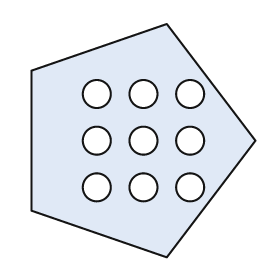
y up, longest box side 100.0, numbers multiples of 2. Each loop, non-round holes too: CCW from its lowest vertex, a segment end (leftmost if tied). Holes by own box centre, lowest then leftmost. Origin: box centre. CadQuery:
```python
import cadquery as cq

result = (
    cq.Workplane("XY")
    .moveTo(10.0, -50.0)
    .lineTo(48.0, 0.0)
    .lineTo(10.0, 50.0)
    .lineTo(-48.0, 30.0)
    .lineTo(-48.0, -30.0)
    .close()
    .moveTo(-20.0, -20.0)
    .circle(6.0)
    .moveTo(0.0, -20.0)
    .circle(6.0)
    .moveTo(20.0, -20.0)
    .circle(6.0)
    .moveTo(-20.0, 0.0)
    .circle(6.0)
    .moveTo(0.0, 0.0)
    .circle(6.0)
    .moveTo(20.0, 0.0)
    .circle(6.0)
    .moveTo(-20.0, 20.0)
    .circle(6.0)
    .moveTo(0.0, 20.0)
    .circle(6.0)
    .moveTo(20.0, 20.0)
    .circle(6.0)
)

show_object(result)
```